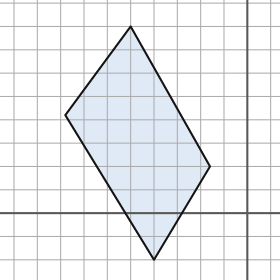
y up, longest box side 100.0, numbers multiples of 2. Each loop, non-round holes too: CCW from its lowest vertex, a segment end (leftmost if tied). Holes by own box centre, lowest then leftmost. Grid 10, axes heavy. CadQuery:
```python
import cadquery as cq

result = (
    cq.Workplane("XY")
    .moveTo(-40.0, -20.0)
    .lineTo(-16.0, 20.0)
    .lineTo(-50.0, 80.0)
    .lineTo(-78.0, 42.0)
    .close()
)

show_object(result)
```